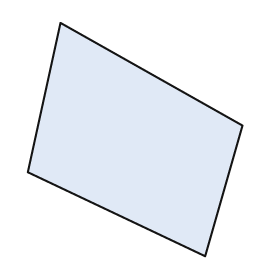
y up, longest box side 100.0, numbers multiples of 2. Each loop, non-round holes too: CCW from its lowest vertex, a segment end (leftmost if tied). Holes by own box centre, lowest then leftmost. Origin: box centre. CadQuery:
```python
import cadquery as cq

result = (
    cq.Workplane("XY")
    .moveTo(30.0, -50.0)
    .lineTo(46.0, 6.0)
    .lineTo(-32.0, 50.0)
    .lineTo(-46.0, -14.0)
    .close()
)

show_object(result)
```